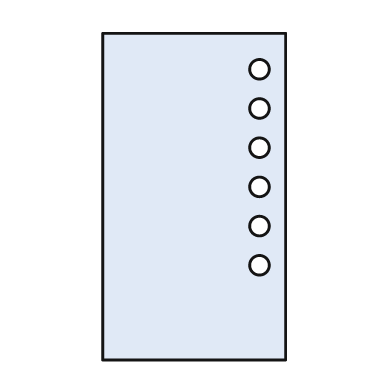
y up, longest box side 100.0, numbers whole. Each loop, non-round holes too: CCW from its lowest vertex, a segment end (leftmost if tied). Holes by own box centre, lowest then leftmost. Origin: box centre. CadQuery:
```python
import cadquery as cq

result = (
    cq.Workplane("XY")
    .moveTo(-28.0, -50.0)
    .lineTo(28.0, -50.0)
    .lineTo(28.0, 50.0)
    .lineTo(-28.0, 50.0)
    .close()
    .moveTo(20.0, -21.0)
    .circle(3.0)
    .moveTo(20.0, -9.0)
    .circle(3.0)
    .moveTo(20.0, 3.0)
    .circle(3.0)
    .moveTo(20.0, 15.0)
    .circle(3.0)
    .moveTo(20.0, 27.0)
    .circle(3.0)
    .moveTo(20.0, 39.0)
    .circle(3.0)
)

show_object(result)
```